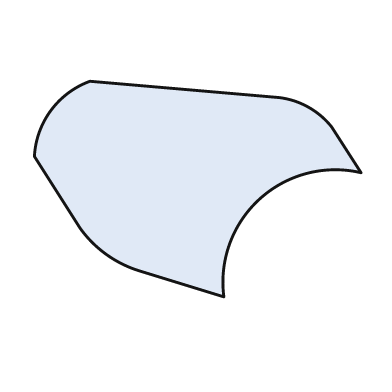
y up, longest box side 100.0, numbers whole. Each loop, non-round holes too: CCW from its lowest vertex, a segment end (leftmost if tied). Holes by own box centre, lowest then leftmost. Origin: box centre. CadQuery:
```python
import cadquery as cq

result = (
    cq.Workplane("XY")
    .moveTo(8.0, -33.0)
    .threePointArc((19.0, -3.0), (50.0, 5.0))
    .lineTo(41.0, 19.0)
    .threePointArc((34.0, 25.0), (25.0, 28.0))
    .lineTo(-33.0, 33.0)
    .threePointArc((-45.0, 24.0), (-50.0, 10.0))
    .lineTo(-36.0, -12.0)
    .threePointArc((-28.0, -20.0), (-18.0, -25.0))
    .close()
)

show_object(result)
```